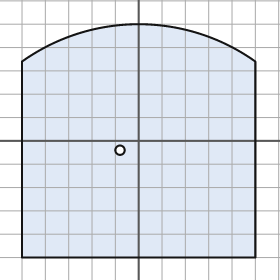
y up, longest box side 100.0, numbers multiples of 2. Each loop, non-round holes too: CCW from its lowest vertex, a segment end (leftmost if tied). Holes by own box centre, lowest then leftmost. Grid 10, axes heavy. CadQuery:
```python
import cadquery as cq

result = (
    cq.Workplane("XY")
    .moveTo(-50.0, -50.0)
    .lineTo(50.0, -50.0)
    .lineTo(50.0, 34.0)
    .threePointArc((0.0, 50.0), (-50.0, 34.0))
    .close()
    .moveTo(-8.0, -4.0)
    .circle(2.0)
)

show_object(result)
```